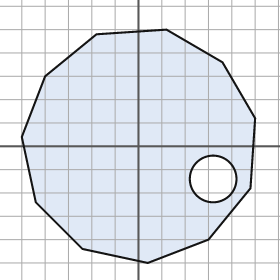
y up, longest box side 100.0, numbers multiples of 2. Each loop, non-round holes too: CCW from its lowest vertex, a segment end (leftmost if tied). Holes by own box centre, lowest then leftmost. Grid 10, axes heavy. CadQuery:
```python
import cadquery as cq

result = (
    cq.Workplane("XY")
    .moveTo(4.0, -50.0)
    .lineTo(30.0, -40.0)
    .lineTo(48.0, -18.0)
    .lineTo(50.0, 12.0)
    .lineTo(36.0, 36.0)
    .lineTo(12.0, 50.0)
    .lineTo(-18.0, 48.0)
    .lineTo(-40.0, 30.0)
    .lineTo(-50.0, 4.0)
    .lineTo(-44.0, -24.0)
    .lineTo(-24.0, -44.0)
    .close()
    .moveTo(32.0, -14.0)
    .circle(10.0)
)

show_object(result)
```